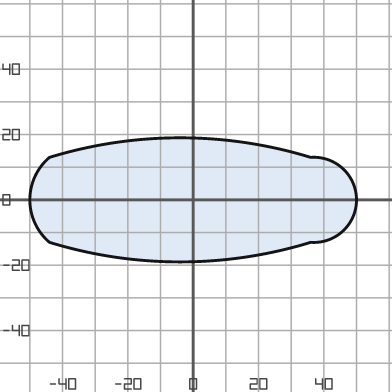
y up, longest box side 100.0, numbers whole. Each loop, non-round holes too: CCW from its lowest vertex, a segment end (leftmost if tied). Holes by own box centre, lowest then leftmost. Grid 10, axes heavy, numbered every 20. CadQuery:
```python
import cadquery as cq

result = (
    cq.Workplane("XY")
    .moveTo(-44.0, -13.0)
    .threePointArc((-4.0, -19.0), (36.0, -13.0))
    .threePointArc((50.0, 0.0), (36.0, 13.0))
    .threePointArc((-4.0, 19.0), (-44.0, 13.0))
    .threePointArc((-50.0, 0.0), (-44.0, -13.0))
    .close()
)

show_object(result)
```